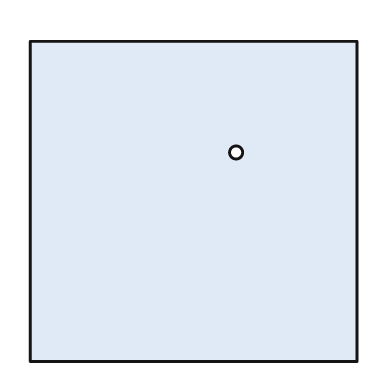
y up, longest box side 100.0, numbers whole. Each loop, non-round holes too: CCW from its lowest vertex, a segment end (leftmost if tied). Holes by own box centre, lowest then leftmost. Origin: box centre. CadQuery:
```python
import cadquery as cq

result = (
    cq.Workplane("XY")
    .moveTo(-50.0, -49.0)
    .lineTo(50.0, -49.0)
    .lineTo(50.0, 49.0)
    .lineTo(-50.0, 49.0)
    .close()
    .moveTo(13.0, 15.0)
    .circle(2.0)
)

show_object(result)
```